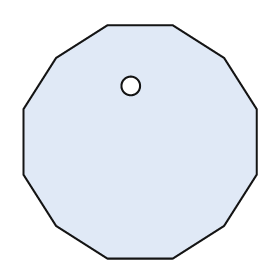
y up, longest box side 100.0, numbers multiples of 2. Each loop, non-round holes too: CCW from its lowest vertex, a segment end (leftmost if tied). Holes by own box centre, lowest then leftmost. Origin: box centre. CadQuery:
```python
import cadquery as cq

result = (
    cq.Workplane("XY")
    .moveTo(-14.0, -50.0)
    .lineTo(14.0, -50.0)
    .lineTo(36.0, -36.0)
    .lineTo(50.0, -14.0)
    .lineTo(50.0, 14.0)
    .lineTo(36.0, 36.0)
    .lineTo(14.0, 50.0)
    .lineTo(-14.0, 50.0)
    .lineTo(-36.0, 36.0)
    .lineTo(-50.0, 14.0)
    .lineTo(-50.0, -14.0)
    .lineTo(-36.0, -36.0)
    .close()
    .moveTo(-4.0, 24.0)
    .circle(4.0)
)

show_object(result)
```